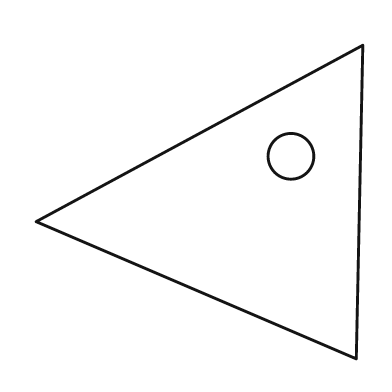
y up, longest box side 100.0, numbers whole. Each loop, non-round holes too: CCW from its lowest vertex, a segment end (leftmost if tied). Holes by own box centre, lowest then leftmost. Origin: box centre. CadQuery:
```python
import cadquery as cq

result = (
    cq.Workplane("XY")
    .moveTo(48.0, -48.0)
    .lineTo(50.0, 48.0)
    .lineTo(-50.0, -6.0)
    .close()
    .moveTo(28.0, 14.0)
    .circle(7.0)
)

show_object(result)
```